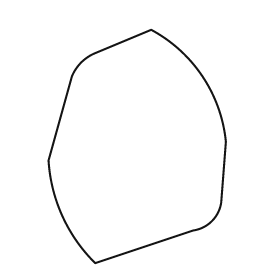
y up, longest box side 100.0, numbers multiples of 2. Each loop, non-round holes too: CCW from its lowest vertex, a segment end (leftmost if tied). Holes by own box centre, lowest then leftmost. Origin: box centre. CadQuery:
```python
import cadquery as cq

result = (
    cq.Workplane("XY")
    .moveTo(-18.0, -50.0)
    .lineTo(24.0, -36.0)
    .threePointArc((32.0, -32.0), (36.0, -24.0))
    .lineTo(38.0, 2.0)
    .threePointArc((28.0, 30.0), (6.0, 50.0))
    .lineTo(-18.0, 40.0)
    .threePointArc((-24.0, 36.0), (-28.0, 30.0))
    .lineTo(-38.0, -6.0)
    .threePointArc((-32.0, -30.0), (-18.0, -50.0))
    .close()
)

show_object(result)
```